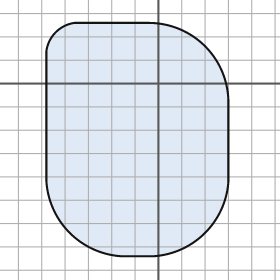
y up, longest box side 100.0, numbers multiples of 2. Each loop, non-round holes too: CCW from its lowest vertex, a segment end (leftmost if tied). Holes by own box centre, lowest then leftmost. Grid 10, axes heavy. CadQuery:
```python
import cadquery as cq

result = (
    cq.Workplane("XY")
    .moveTo(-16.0, -74.0)
    .lineTo(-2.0, -74.0)
    .threePointArc((20.0, -64.0), (30.0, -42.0))
    .lineTo(30.0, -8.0)
    .threePointArc((20.0, 16.0), (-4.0, 26.0))
    .lineTo(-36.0, 26.0)
    .threePointArc((-44.0, 22.0), (-48.0, 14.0))
    .lineTo(-48.0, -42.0)
    .threePointArc((-38.0, -64.0), (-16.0, -74.0))
    .close()
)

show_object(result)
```